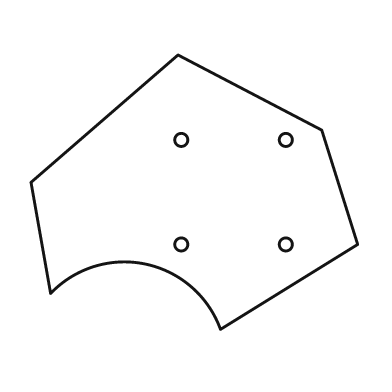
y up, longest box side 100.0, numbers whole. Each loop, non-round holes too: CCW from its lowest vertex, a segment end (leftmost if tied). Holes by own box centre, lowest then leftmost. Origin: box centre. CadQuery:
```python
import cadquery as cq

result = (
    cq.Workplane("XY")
    .moveTo(8.0, -42.0)
    .lineTo(50.0, -16.0)
    .lineTo(39.0, 19.0)
    .lineTo(-5.0, 42.0)
    .lineTo(-50.0, 3.0)
    .lineTo(-44.0, -31.0)
    .threePointArc((-15.0, -22.0), (8.0, -42.0))
    .close()
    .moveTo(-4.0, -16.0)
    .circle(2.0)
    .moveTo(28.0, -16.0)
    .circle(2.0)
    .moveTo(-4.0, 16.0)
    .circle(2.0)
    .moveTo(28.0, 16.0)
    .circle(2.0)
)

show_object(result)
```